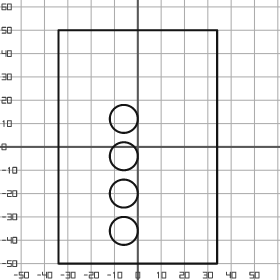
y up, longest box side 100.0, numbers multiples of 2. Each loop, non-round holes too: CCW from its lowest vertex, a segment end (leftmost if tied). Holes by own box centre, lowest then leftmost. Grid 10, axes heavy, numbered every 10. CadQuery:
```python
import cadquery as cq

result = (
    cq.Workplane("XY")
    .moveTo(-34.0, -50.0)
    .lineTo(34.0, -50.0)
    .lineTo(34.0, 50.0)
    .lineTo(-34.0, 50.0)
    .close()
    .moveTo(-6.0, -36.0)
    .circle(6.0)
    .moveTo(-6.0, -20.0)
    .circle(6.0)
    .moveTo(-6.0, -4.0)
    .circle(6.0)
    .moveTo(-6.0, 12.0)
    .circle(6.0)
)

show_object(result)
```